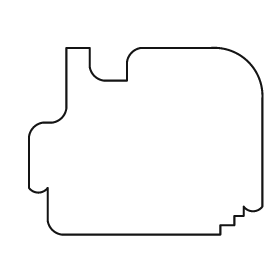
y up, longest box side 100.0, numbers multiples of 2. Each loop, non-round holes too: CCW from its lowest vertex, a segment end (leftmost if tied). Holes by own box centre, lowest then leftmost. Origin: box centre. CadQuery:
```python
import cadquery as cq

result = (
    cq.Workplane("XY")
    .moveTo(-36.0, -40.0)
    .lineTo(32.0, -40.0)
    .lineTo(32.0, -36.0)
    .lineTo(38.0, -36.0)
    .lineTo(38.0, -32.0)
    .lineTo(42.0, -32.0)
    .lineTo(42.0, -28.0)
    .threePointArc((46.0, -30.0), (50.0, -28.0))
    .lineTo(50.0, 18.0)
    .threePointArc((44.0, 34.0), (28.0, 40.0))
    .lineTo(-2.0, 40.0)
    .threePointArc((-6.0, 38.0), (-8.0, 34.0))
    .lineTo(-8.0, 26.0)
    .lineTo(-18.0, 26.0)
    .threePointArc((-22.0, 28.0), (-24.0, 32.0))
    .lineTo(-24.0, 40.0)
    .lineTo(-34.0, 40.0)
    .lineTo(-34.0, 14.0)
    .threePointArc((-36.0, 10.0), (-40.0, 8.0))
    .lineTo(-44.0, 8.0)
    .threePointArc((-48.0, 6.0), (-50.0, 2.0))
    .lineTo(-50.0, -20.0)
    .threePointArc((-46.0, -22.0), (-42.0, -20.0))
    .lineTo(-42.0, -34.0)
    .threePointArc((-40.0, -38.0), (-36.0, -40.0))
    .close()
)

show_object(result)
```